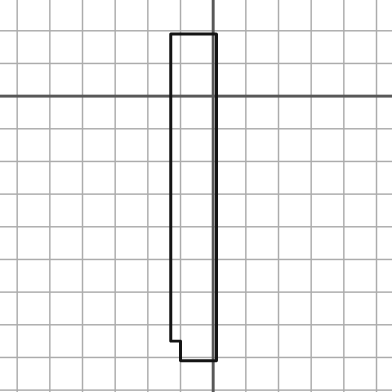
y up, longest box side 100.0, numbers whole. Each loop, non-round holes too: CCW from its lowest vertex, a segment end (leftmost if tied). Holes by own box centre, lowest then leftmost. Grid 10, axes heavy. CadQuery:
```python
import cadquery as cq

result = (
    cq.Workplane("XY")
    .moveTo(-10.0, -81.0)
    .lineTo(1.0, -81.0)
    .lineTo(1.0, 19.0)
    .lineTo(-13.0, 19.0)
    .lineTo(-13.0, -75.0)
    .lineTo(-10.0, -75.0)
    .close()
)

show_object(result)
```